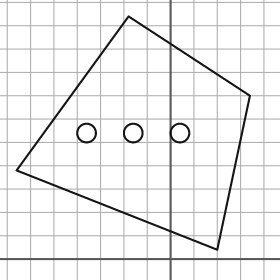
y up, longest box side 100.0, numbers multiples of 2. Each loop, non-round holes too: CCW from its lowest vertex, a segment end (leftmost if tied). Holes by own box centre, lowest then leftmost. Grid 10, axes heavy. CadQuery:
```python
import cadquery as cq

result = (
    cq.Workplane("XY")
    .moveTo(20.0, 4.0)
    .lineTo(34.0, 70.0)
    .lineTo(-18.0, 104.0)
    .lineTo(-66.0, 38.0)
    .close()
    .moveTo(-36.0, 54.0)
    .circle(4.0)
    .moveTo(-16.0, 54.0)
    .circle(4.0)
    .moveTo(4.0, 54.0)
    .circle(4.0)
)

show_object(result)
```